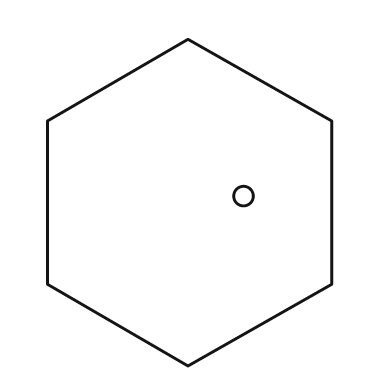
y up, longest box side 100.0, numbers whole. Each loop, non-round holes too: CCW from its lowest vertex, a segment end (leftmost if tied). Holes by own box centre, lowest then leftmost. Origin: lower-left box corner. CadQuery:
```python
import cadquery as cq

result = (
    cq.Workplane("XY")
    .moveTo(43.0, 0.0)
    .lineTo(87.0, 25.0)
    .lineTo(87.0, 75.0)
    .lineTo(43.0, 100.0)
    .lineTo(0.0, 75.0)
    .lineTo(0.0, 25.0)
    .close()
    .moveTo(60.0, 52.0)
    .circle(3.0)
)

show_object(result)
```